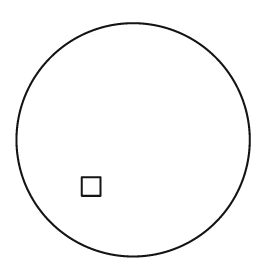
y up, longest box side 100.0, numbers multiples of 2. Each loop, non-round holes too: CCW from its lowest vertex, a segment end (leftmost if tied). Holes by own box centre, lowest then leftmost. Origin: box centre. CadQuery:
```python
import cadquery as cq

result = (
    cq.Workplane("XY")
    .moveTo(0.0, 0.0)
    .circle(50.0)
    .moveTo(-22.0, -24.0)
    .lineTo(-14.0, -24.0)
    .lineTo(-14.0, -16.0)
    .lineTo(-22.0, -16.0)
    .close()
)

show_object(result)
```